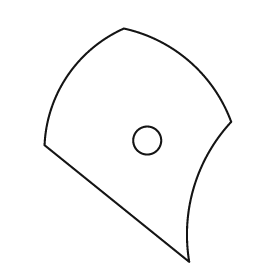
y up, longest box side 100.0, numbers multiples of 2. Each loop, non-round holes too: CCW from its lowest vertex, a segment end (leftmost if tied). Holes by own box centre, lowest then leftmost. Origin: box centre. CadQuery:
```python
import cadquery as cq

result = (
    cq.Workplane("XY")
    .moveTo(22.0, -50.0)
    .threePointArc((24.0, -18.0), (40.0, 10.0))
    .threePointArc((22.0, 36.0), (-6.0, 50.0))
    .threePointArc((-30.0, 30.0), (-40.0, 0.0))
    .close()
    .moveTo(4.0, 2.0)
    .circle(6.0)
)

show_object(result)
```